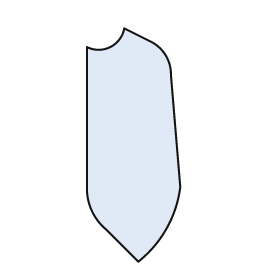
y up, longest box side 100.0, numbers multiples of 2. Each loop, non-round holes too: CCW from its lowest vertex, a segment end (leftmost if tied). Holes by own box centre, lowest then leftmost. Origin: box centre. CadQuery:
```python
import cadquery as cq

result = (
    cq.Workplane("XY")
    .moveTo(2.0, -50.0)
    .threePointArc((14.0, -36.0), (20.0, -18.0))
    .lineTo(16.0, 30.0)
    .threePointArc((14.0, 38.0), (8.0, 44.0))
    .lineTo(-4.0, 50.0)
    .threePointArc((-10.0, 42.0), (-20.0, 42.0))
    .lineTo(-20.0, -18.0)
    .threePointArc((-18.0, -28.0), (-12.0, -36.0))
    .close()
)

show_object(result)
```